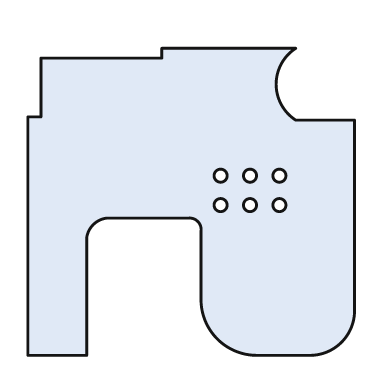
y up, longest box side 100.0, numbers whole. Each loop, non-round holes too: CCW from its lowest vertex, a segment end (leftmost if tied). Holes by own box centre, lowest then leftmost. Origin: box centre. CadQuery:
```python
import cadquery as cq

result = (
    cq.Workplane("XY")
    .moveTo(-50.0, -47.0)
    .lineTo(-32.0, -47.0)
    .lineTo(-32.0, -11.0)
    .threePointArc((-30.0, -7.0), (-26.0, -5.0))
    .lineTo(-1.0, -5.0)
    .threePointArc((2.0, -6.0), (3.0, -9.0))
    .lineTo(3.0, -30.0)
    .threePointArc((8.0, -42.0), (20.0, -47.0))
    .lineTo(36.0, -47.0)
    .threePointArc((46.0, -43.0), (50.0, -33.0))
    .lineTo(50.0, 25.0)
    .lineTo(32.0, 25.0)
    .threePointArc((26.0, 36.0), (32.0, 47.0))
    .lineTo(-9.0, 47.0)
    .lineTo(-9.0, 44.0)
    .lineTo(-46.0, 44.0)
    .lineTo(-46.0, 26.0)
    .lineTo(-50.0, 26.0)
    .close()
    .moveTo(9.0, -1.0)
    .circle(2.0)
    .moveTo(18.0, -1.0)
    .circle(2.0)
    .moveTo(27.0, -1.0)
    .circle(2.0)
    .moveTo(9.0, 8.0)
    .circle(2.0)
    .moveTo(18.0, 8.0)
    .circle(2.0)
    .moveTo(27.0, 8.0)
    .circle(2.0)
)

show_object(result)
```